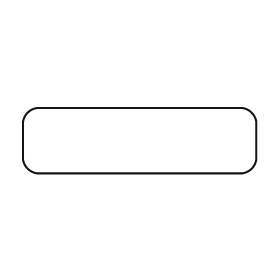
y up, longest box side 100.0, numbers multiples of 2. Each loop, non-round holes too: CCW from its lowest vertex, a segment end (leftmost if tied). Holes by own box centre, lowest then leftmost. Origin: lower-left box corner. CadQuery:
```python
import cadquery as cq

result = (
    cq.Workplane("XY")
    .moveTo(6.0, 0.0)
    .lineTo(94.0, 0.0)
    .threePointArc((98.0, 2.0), (100.0, 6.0))
    .lineTo(100.0, 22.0)
    .threePointArc((98.0, 26.0), (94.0, 28.0))
    .lineTo(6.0, 28.0)
    .threePointArc((2.0, 26.0), (0.0, 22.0))
    .lineTo(0.0, 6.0)
    .threePointArc((2.0, 2.0), (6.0, 0.0))
    .close()
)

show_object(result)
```